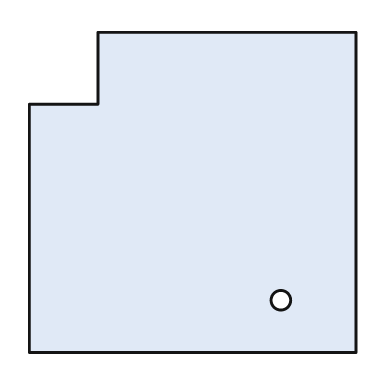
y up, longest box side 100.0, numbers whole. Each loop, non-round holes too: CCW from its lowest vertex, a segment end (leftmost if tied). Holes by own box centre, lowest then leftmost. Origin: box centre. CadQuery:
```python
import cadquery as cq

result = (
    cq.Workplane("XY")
    .moveTo(-50.0, -49.0)
    .lineTo(50.0, -49.0)
    .lineTo(50.0, 49.0)
    .lineTo(-29.0, 49.0)
    .lineTo(-29.0, 27.0)
    .lineTo(-50.0, 27.0)
    .close()
    .moveTo(27.0, -33.0)
    .circle(3.0)
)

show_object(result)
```